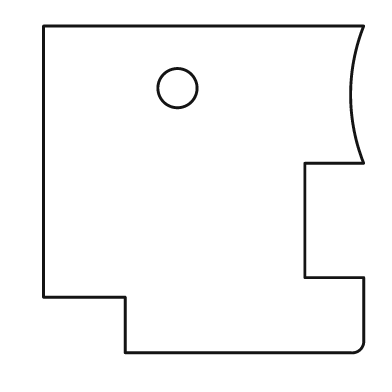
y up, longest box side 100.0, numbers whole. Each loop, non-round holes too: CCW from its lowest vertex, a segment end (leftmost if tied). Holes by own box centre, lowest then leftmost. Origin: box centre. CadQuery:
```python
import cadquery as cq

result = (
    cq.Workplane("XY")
    .moveTo(-24.0, -50.0)
    .lineTo(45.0, -50.0)
    .threePointArc((48.0, -49.0), (49.0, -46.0))
    .lineTo(49.0, -27.0)
    .lineTo(31.0, -27.0)
    .lineTo(31.0, 8.0)
    .lineTo(49.0, 8.0)
    .threePointArc((45.0, 29.0), (49.0, 50.0))
    .lineTo(-49.0, 50.0)
    .lineTo(-49.0, -33.0)
    .lineTo(-24.0, -33.0)
    .close()
    .moveTo(-8.0, 31.0)
    .circle(6.0)
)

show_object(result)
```